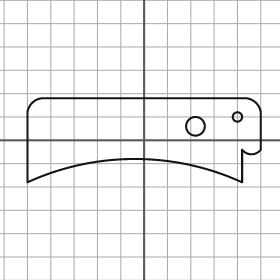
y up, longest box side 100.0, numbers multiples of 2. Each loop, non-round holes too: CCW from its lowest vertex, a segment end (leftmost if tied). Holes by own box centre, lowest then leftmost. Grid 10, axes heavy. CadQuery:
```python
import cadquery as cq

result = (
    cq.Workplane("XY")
    .moveTo(-50.0, -18.0)
    .threePointArc((-4.0, -8.0), (42.0, -18.0))
    .lineTo(42.0, -4.0)
    .threePointArc((46.0, -6.0), (50.0, -4.0))
    .lineTo(50.0, 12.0)
    .threePointArc((48.0, 16.0), (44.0, 18.0))
    .lineTo(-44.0, 18.0)
    .threePointArc((-48.0, 16.0), (-50.0, 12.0))
    .close()
    .moveTo(22.0, 6.0)
    .circle(4.0)
    .moveTo(40.0, 10.0)
    .circle(2.0)
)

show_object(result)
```